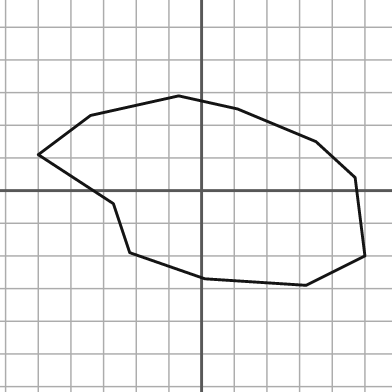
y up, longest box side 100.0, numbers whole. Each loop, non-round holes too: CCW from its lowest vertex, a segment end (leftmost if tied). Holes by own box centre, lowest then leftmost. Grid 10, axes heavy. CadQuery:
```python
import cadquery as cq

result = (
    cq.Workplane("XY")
    .moveTo(32.0, -29.0)
    .lineTo(50.0, -20.0)
    .lineTo(47.0, 4.0)
    .lineTo(35.0, 15.0)
    .lineTo(11.0, 25.0)
    .lineTo(-7.0, 29.0)
    .lineTo(-34.0, 23.0)
    .lineTo(-50.0, 11.0)
    .lineTo(-27.0, -4.0)
    .lineTo(-22.0, -19.0)
    .lineTo(1.0, -27.0)
    .close()
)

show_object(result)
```